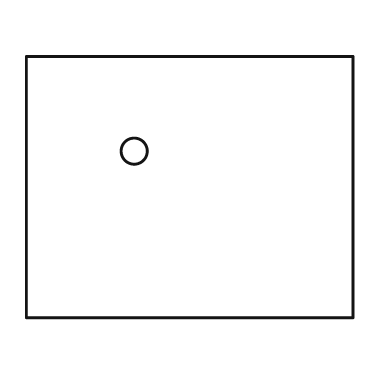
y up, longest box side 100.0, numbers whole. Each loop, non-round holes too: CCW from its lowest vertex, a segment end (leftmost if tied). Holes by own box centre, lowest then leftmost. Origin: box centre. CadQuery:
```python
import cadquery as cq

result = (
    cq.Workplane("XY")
    .moveTo(-50.0, -40.0)
    .lineTo(50.0, -40.0)
    .lineTo(50.0, 40.0)
    .lineTo(-50.0, 40.0)
    .close()
    .moveTo(-17.0, 11.0)
    .circle(4.0)
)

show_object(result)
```